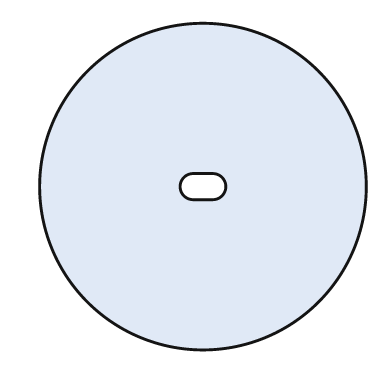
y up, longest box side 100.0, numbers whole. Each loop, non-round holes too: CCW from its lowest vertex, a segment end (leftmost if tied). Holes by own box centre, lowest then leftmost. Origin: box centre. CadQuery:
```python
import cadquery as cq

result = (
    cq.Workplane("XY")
    .moveTo(0.0, 0.0)
    .circle(50.0)
    .moveTo(-3.0, -4.0)
    .lineTo(3.0, -4.0)
    .threePointArc((7.0, 0.0), (3.0, 4.0))
    .lineTo(-3.0, 4.0)
    .threePointArc((-7.0, 0.0), (-3.0, -4.0))
    .close()
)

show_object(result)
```